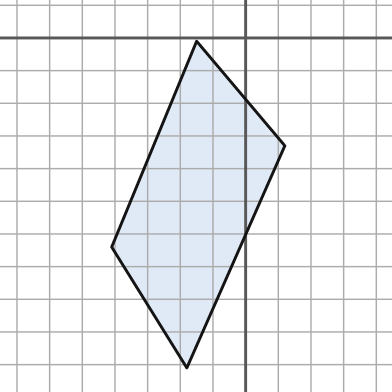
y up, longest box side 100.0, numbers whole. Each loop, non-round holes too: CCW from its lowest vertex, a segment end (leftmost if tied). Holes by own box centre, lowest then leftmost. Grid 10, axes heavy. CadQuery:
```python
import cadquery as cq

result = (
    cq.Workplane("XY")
    .moveTo(-18.0, -101.0)
    .lineTo(12.0, -33.0)
    .lineTo(-15.0, -1.0)
    .lineTo(-41.0, -64.0)
    .close()
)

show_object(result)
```